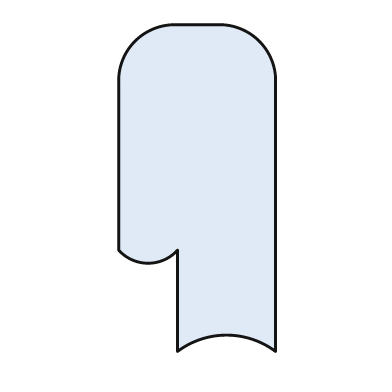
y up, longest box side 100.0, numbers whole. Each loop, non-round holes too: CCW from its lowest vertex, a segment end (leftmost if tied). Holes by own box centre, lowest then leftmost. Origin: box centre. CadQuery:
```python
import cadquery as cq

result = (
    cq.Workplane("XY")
    .moveTo(-6.0, -50.0)
    .threePointArc((9.0, -45.0), (24.0, -50.0))
    .lineTo(24.0, 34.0)
    .threePointArc((19.0, 45.0), (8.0, 50.0))
    .lineTo(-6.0, 50.0)
    .threePointArc((-19.0, 45.0), (-24.0, 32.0))
    .lineTo(-24.0, -19.0)
    .threePointArc((-15.0, -23.0), (-6.0, -19.0))
    .close()
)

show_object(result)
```